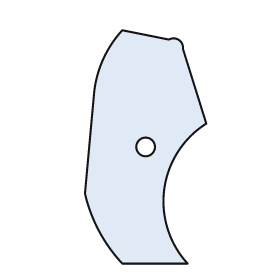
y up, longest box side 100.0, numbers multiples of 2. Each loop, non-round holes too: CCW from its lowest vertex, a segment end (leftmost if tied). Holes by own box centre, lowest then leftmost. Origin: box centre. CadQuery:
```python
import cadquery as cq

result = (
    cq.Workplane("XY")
    .moveTo(-10.0, -50.0)
    .lineTo(18.0, -50.0)
    .threePointArc((8.0, -18.0), (26.0, 10.0))
    .lineTo(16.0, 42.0)
    .threePointArc((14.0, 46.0), (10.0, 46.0))
    .lineTo(-10.0, 50.0)
    .threePointArc((-18.0, 38.0), (-22.0, 24.0))
    .lineTo(-26.0, -20.0)
    .threePointArc((-20.0, -36.0), (-10.0, -50.0))
    .close()
    .moveTo(0.0, 0.0)
    .circle(4.0)
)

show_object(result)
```